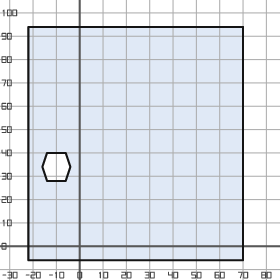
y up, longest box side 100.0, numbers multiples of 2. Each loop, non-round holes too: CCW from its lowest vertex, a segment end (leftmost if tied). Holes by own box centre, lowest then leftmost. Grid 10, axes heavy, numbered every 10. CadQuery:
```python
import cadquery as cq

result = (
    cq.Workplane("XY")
    .moveTo(-22.0, -6.0)
    .lineTo(70.0, -6.0)
    .lineTo(70.0, 94.0)
    .lineTo(-22.0, 94.0)
    .close()
    .moveTo(-14.0, 28.0)
    .lineTo(-6.0, 28.0)
    .lineTo(-4.0, 34.0)
    .lineTo(-6.0, 40.0)
    .lineTo(-14.0, 40.0)
    .lineTo(-16.0, 34.0)
    .close()
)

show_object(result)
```